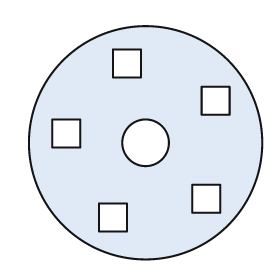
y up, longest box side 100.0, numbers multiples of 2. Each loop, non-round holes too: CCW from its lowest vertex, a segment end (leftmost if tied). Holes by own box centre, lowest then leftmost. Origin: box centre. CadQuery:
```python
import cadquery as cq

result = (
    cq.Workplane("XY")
    .moveTo(0.0, 0.0)
    .circle(50.0)
    .moveTo(-20.0, -38.0)
    .lineTo(-8.0, -38.0)
    .lineTo(-8.0, -26.0)
    .lineTo(-20.0, -26.0)
    .close()
    .moveTo(20.0, -30.0)
    .lineTo(32.0, -30.0)
    .lineTo(32.0, -18.0)
    .lineTo(20.0, -18.0)
    .close()
    .moveTo(0.0, 0.0)
    .circle(10.0)
    .moveTo(-40.0, -2.0)
    .lineTo(-28.0, -2.0)
    .lineTo(-28.0, 10.0)
    .lineTo(-40.0, 10.0)
    .close()
    .moveTo(24.0, 12.0)
    .lineTo(36.0, 12.0)
    .lineTo(36.0, 24.0)
    .lineTo(24.0, 24.0)
    .close()
    .moveTo(-14.0, 28.0)
    .lineTo(-2.0, 28.0)
    .lineTo(-2.0, 40.0)
    .lineTo(-14.0, 40.0)
    .close()
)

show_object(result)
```